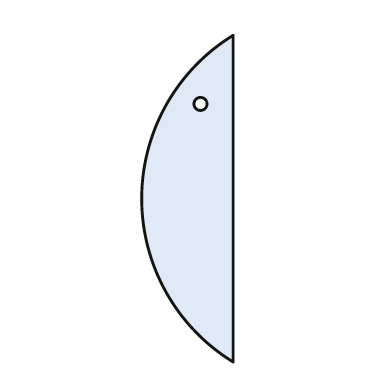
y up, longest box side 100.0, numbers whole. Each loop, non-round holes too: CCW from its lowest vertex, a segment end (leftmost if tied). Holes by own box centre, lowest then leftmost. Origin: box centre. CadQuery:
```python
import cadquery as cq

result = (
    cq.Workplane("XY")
    .moveTo(14.0, -50.0)
    .lineTo(14.0, 50.0)
    .threePointArc((-14.0, 0.0), (14.0, -50.0))
    .close()
    .moveTo(4.0, 29.0)
    .circle(2.0)
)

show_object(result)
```